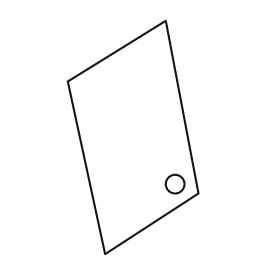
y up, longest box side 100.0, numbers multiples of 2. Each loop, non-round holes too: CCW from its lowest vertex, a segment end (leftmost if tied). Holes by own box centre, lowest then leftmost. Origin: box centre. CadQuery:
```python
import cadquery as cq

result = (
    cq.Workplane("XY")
    .moveTo(-12.0, -50.0)
    .lineTo(28.0, -24.0)
    .lineTo(14.0, 50.0)
    .lineTo(-28.0, 24.0)
    .close()
    .moveTo(18.0, -20.0)
    .circle(4.0)
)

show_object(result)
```